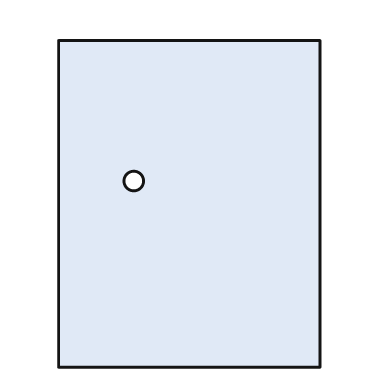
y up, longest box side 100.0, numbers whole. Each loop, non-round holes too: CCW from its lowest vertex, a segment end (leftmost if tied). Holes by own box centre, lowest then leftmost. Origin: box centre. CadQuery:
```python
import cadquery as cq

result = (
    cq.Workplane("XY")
    .moveTo(-40.0, -50.0)
    .lineTo(40.0, -50.0)
    .lineTo(40.0, 50.0)
    .lineTo(-40.0, 50.0)
    .close()
    .moveTo(-17.0, 7.0)
    .circle(3.0)
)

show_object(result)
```